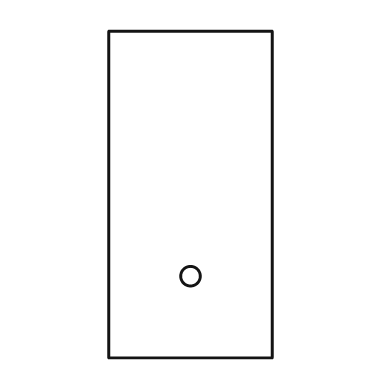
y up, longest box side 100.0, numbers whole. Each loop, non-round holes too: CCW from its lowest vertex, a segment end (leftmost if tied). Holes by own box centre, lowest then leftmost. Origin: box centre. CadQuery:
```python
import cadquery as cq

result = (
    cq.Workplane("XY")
    .moveTo(-25.0, -50.0)
    .lineTo(25.0, -50.0)
    .lineTo(25.0, 50.0)
    .lineTo(-25.0, 50.0)
    .close()
    .moveTo(0.0, -25.0)
    .circle(3.0)
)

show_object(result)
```